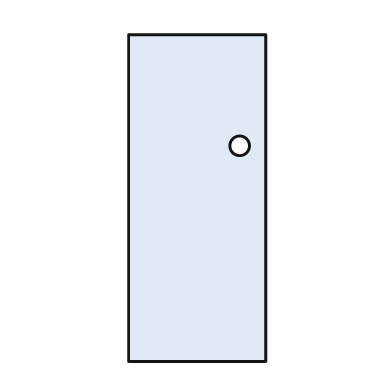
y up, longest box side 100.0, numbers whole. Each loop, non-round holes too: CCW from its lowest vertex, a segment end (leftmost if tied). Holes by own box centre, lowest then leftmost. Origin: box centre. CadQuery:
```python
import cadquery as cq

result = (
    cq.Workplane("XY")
    .moveTo(-21.0, -50.0)
    .lineTo(21.0, -50.0)
    .lineTo(21.0, 50.0)
    .lineTo(-21.0, 50.0)
    .close()
    .moveTo(13.0, 16.0)
    .circle(3.0)
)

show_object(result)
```